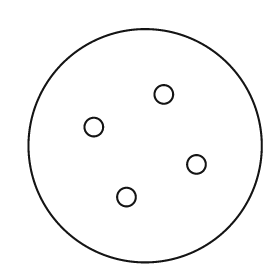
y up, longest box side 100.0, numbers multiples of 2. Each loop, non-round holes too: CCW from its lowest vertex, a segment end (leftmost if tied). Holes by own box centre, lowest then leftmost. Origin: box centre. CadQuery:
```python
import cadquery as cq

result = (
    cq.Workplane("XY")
    .moveTo(0.0, 0.0)
    .circle(50.0)
    .moveTo(-8.0, -22.0)
    .circle(4.0)
    .moveTo(22.0, -8.0)
    .circle(4.0)
    .moveTo(-22.0, 8.0)
    .circle(4.0)
    .moveTo(8.0, 22.0)
    .circle(4.0)
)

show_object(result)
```